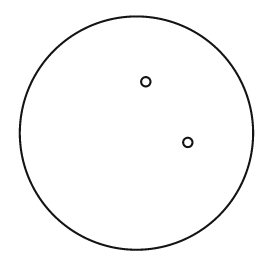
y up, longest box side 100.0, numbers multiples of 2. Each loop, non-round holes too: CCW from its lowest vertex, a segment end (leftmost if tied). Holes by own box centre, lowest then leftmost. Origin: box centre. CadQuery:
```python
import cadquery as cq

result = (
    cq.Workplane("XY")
    .moveTo(0.0, 0.0)
    .circle(50.0)
    .moveTo(22.0, -4.0)
    .circle(2.0)
    .moveTo(4.0, 22.0)
    .circle(2.0)
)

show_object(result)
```